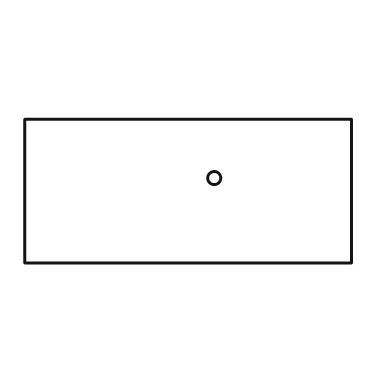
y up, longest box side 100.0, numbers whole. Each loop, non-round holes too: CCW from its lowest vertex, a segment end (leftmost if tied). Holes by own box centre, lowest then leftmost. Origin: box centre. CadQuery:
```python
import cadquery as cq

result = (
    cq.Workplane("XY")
    .moveTo(-50.0, -22.0)
    .lineTo(50.0, -22.0)
    .lineTo(50.0, 22.0)
    .lineTo(-50.0, 22.0)
    .close()
    .moveTo(8.0, 4.0)
    .circle(2.0)
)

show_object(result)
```